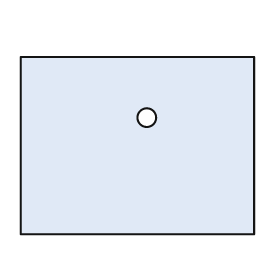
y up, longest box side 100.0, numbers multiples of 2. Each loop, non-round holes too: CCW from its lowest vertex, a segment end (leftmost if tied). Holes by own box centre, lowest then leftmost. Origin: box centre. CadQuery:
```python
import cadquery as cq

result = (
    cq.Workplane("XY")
    .moveTo(-50.0, -38.0)
    .lineTo(50.0, -38.0)
    .lineTo(50.0, 38.0)
    .lineTo(-50.0, 38.0)
    .close()
    .moveTo(4.0, 12.0)
    .circle(4.0)
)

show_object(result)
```